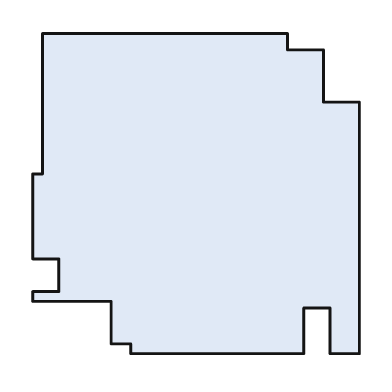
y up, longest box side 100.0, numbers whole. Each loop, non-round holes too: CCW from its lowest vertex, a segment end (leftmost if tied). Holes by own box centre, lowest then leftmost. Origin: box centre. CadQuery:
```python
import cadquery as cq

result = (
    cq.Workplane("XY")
    .moveTo(-20.0, -49.0)
    .lineTo(33.0, -49.0)
    .lineTo(33.0, -35.0)
    .lineTo(41.0, -35.0)
    .lineTo(41.0, -49.0)
    .lineTo(50.0, -49.0)
    .lineTo(50.0, 28.0)
    .lineTo(39.0, 28.0)
    .lineTo(39.0, 44.0)
    .lineTo(28.0, 44.0)
    .lineTo(28.0, 49.0)
    .lineTo(-47.0, 49.0)
    .lineTo(-47.0, 6.0)
    .lineTo(-50.0, 6.0)
    .lineTo(-50.0, -20.0)
    .lineTo(-42.0, -20.0)
    .lineTo(-42.0, -30.0)
    .lineTo(-50.0, -30.0)
    .lineTo(-50.0, -33.0)
    .lineTo(-26.0, -33.0)
    .lineTo(-26.0, -46.0)
    .lineTo(-20.0, -46.0)
    .close()
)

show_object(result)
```